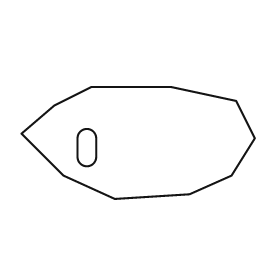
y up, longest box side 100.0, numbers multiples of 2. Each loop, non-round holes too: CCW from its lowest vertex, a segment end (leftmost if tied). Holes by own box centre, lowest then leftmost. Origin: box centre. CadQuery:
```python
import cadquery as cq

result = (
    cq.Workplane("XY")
    .moveTo(-10.0, -24.0)
    .lineTo(22.0, -22.0)
    .lineTo(40.0, -14.0)
    .lineTo(50.0, 2.0)
    .lineTo(42.0, 18.0)
    .lineTo(14.0, 24.0)
    .lineTo(-20.0, 24.0)
    .lineTo(-36.0, 16.0)
    .lineTo(-50.0, 4.0)
    .lineTo(-32.0, -14.0)
    .close()
    .moveTo(-26.0, -6.0)
    .threePointArc((-22.0, -10.0), (-18.0, -6.0))
    .lineTo(-18.0, 2.0)
    .threePointArc((-22.0, 6.0), (-26.0, 2.0))
    .close()
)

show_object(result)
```